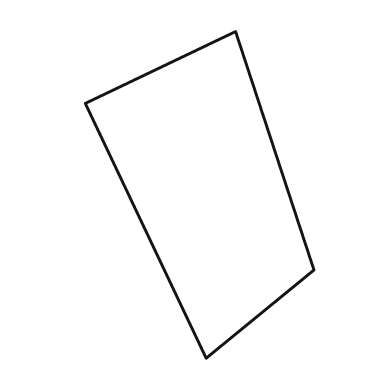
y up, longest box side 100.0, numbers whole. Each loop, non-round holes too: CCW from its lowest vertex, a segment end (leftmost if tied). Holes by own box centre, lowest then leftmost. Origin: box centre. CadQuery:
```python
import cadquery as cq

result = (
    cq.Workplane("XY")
    .moveTo(2.0, -50.0)
    .lineTo(35.0, -23.0)
    .lineTo(11.0, 50.0)
    .lineTo(-35.0, 28.0)
    .close()
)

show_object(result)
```